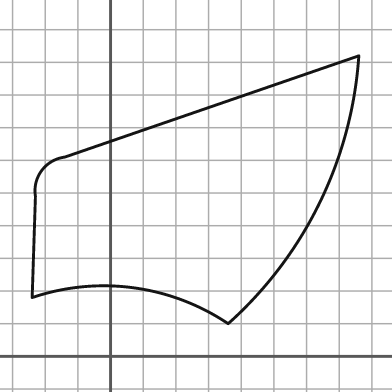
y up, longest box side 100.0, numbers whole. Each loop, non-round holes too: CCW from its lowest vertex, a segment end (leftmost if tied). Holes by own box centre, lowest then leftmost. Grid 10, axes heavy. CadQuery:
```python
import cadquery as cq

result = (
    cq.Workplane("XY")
    .moveTo(36.0, 10.0)
    .threePointArc((64.0, 47.0), (76.0, 92.0))
    .lineTo(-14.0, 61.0)
    .threePointArc((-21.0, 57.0), (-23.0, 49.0))
    .lineTo(-24.0, 18.0)
    .threePointArc((7.0, 21.0), (36.0, 10.0))
    .close()
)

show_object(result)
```